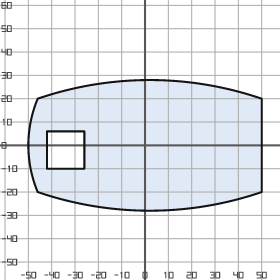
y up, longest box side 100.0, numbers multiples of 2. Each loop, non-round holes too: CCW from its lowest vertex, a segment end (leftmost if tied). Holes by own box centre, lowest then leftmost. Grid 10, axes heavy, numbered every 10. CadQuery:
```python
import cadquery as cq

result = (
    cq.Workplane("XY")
    .moveTo(-46.0, -20.0)
    .threePointArc((2.0, -28.0), (50.0, -20.0))
    .lineTo(50.0, 20.0)
    .threePointArc((2.0, 28.0), (-46.0, 20.0))
    .threePointArc((-50.0, 0.0), (-46.0, -20.0))
    .close()
    .moveTo(-42.0, -10.0)
    .lineTo(-26.0, -10.0)
    .lineTo(-26.0, 6.0)
    .lineTo(-42.0, 6.0)
    .close()
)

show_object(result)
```